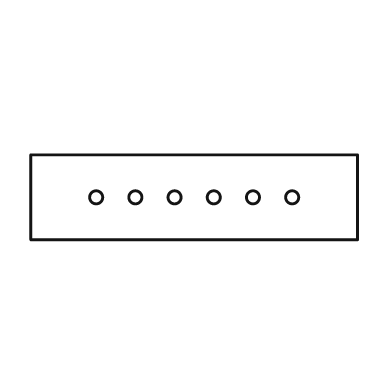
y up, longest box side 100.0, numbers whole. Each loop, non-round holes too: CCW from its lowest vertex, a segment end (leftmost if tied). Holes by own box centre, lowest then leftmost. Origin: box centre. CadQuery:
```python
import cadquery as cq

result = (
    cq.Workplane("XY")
    .moveTo(-50.0, -13.0)
    .lineTo(50.0, -13.0)
    .lineTo(50.0, 13.0)
    .lineTo(-50.0, 13.0)
    .close()
    .moveTo(-30.0, 0.0)
    .circle(2.0)
    .moveTo(-18.0, 0.0)
    .circle(2.0)
    .moveTo(-6.0, 0.0)
    .circle(2.0)
    .moveTo(6.0, 0.0)
    .circle(2.0)
    .moveTo(18.0, 0.0)
    .circle(2.0)
    .moveTo(30.0, 0.0)
    .circle(2.0)
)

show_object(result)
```